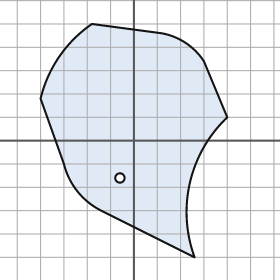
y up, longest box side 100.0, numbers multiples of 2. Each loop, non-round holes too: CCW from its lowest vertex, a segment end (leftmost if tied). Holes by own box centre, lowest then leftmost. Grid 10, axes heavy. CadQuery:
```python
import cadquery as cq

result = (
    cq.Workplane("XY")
    .moveTo(26.0, -50.0)
    .threePointArc((24.0, -18.0), (40.0, 10.0))
    .lineTo(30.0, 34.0)
    .threePointArc((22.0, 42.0), (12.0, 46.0))
    .lineTo(-18.0, 50.0)
    .threePointArc((-32.0, 36.0), (-40.0, 18.0))
    .lineTo(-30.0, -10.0)
    .threePointArc((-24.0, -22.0), (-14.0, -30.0))
    .close()
    .moveTo(-6.0, -16.0)
    .circle(2.0)
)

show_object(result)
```